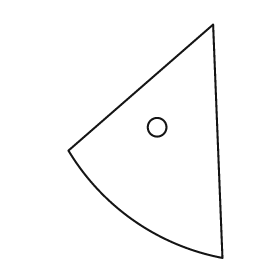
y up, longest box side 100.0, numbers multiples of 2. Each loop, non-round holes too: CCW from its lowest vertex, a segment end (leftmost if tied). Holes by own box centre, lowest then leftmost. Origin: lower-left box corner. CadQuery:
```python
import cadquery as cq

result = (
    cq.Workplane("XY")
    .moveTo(66.0, 0.0)
    .lineTo(62.0, 100.0)
    .lineTo(0.0, 46.0)
    .threePointArc((28.0, 16.0), (66.0, 0.0))
    .close()
    .moveTo(38.0, 56.0)
    .circle(4.0)
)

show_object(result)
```